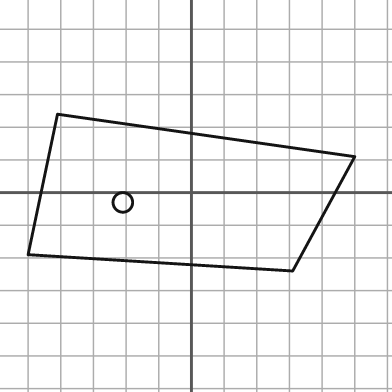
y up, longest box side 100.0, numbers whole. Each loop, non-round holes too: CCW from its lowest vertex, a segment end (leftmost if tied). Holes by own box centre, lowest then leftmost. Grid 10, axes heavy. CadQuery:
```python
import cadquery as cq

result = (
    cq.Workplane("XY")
    .moveTo(31.0, -24.0)
    .lineTo(50.0, 11.0)
    .lineTo(-41.0, 24.0)
    .lineTo(-50.0, -19.0)
    .close()
    .moveTo(-21.0, -3.0)
    .circle(3.0)
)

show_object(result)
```